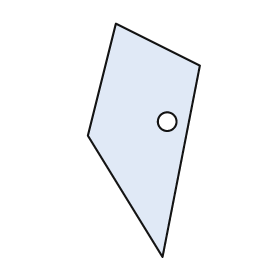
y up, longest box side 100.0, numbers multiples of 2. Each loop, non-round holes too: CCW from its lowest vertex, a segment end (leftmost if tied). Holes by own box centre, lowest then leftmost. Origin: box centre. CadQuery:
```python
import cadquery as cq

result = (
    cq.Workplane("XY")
    .moveTo(8.0, -50.0)
    .lineTo(24.0, 32.0)
    .lineTo(-12.0, 50.0)
    .lineTo(-24.0, 2.0)
    .close()
    .moveTo(10.0, 8.0)
    .circle(4.0)
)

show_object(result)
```